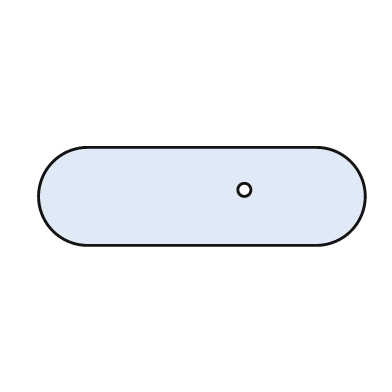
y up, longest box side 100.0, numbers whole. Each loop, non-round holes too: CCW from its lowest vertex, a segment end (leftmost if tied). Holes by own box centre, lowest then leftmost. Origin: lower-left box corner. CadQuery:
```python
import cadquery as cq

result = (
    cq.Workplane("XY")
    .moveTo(15.0, 0.0)
    .lineTo(85.0, 0.0)
    .threePointArc((100.0, 15.0), (85.0, 30.0))
    .lineTo(15.0, 30.0)
    .threePointArc((0.0, 15.0), (15.0, 0.0))
    .close()
    .moveTo(63.0, 17.0)
    .circle(2.0)
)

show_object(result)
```